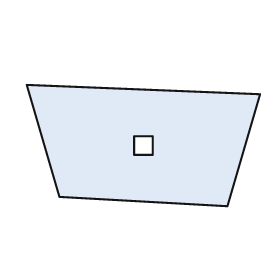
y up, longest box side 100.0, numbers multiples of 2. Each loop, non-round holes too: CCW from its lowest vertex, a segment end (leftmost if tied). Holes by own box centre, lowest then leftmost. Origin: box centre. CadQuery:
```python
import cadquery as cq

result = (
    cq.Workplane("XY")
    .moveTo(36.0, -26.0)
    .lineTo(50.0, 22.0)
    .lineTo(-50.0, 26.0)
    .lineTo(-36.0, -22.0)
    .close()
    .moveTo(-4.0, -4.0)
    .lineTo(4.0, -4.0)
    .lineTo(4.0, 4.0)
    .lineTo(-4.0, 4.0)
    .close()
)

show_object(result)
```